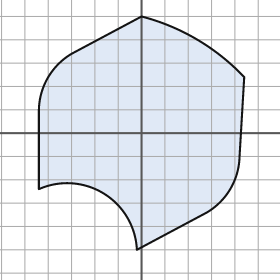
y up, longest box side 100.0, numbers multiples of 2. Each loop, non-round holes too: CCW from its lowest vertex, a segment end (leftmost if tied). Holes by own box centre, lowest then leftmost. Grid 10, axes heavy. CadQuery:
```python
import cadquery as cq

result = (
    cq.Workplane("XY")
    .moveTo(-2.0, -50.0)
    .lineTo(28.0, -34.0)
    .threePointArc((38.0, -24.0), (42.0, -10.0))
    .lineTo(44.0, 24.0)
    .threePointArc((24.0, 40.0), (0.0, 50.0))
    .lineTo(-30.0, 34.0)
    .threePointArc((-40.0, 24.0), (-44.0, 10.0))
    .lineTo(-44.0, -24.0)
    .threePointArc((-16.0, -26.0), (-2.0, -50.0))
    .close()
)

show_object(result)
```